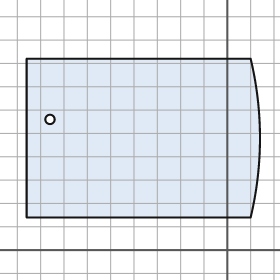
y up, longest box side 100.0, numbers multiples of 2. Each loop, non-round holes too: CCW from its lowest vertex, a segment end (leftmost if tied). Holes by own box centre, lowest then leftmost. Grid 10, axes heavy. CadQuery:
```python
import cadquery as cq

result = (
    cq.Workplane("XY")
    .moveTo(-86.0, 14.0)
    .lineTo(10.0, 14.0)
    .threePointArc((14.0, 48.0), (10.0, 82.0))
    .lineTo(-86.0, 82.0)
    .close()
    .moveTo(-76.0, 56.0)
    .circle(2.0)
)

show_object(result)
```